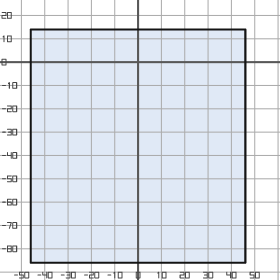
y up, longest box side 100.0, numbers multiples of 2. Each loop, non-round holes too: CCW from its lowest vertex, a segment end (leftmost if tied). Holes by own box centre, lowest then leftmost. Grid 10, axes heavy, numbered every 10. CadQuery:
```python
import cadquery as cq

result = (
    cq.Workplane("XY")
    .moveTo(-46.0, -86.0)
    .lineTo(46.0, -86.0)
    .lineTo(46.0, 14.0)
    .lineTo(-46.0, 14.0)
    .close()
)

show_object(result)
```